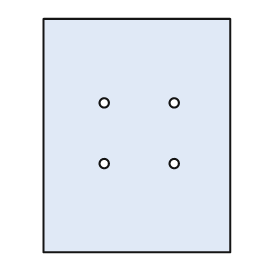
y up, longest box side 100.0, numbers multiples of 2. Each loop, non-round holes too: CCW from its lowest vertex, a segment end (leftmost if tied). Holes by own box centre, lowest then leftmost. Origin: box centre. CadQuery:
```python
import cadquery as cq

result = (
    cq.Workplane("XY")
    .moveTo(-40.0, -50.0)
    .lineTo(40.0, -50.0)
    .lineTo(40.0, 50.0)
    .lineTo(-40.0, 50.0)
    .close()
    .moveTo(-14.0, -12.0)
    .circle(2.0)
    .moveTo(16.0, -12.0)
    .circle(2.0)
    .moveTo(-14.0, 14.0)
    .circle(2.0)
    .moveTo(16.0, 14.0)
    .circle(2.0)
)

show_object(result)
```